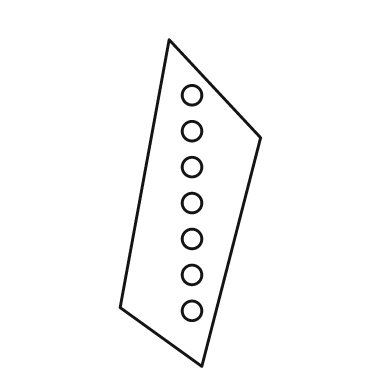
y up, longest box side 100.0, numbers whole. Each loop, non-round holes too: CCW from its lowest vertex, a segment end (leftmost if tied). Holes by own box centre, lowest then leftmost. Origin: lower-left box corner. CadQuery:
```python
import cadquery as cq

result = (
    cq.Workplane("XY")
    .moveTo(25.0, 0.0)
    .lineTo(43.0, 70.0)
    .lineTo(15.0, 100.0)
    .lineTo(0.0, 18.0)
    .close()
    .moveTo(22.0, 17.0)
    .circle(3.0)
    .moveTo(22.0, 28.0)
    .circle(3.0)
    .moveTo(22.0, 39.0)
    .circle(3.0)
    .moveTo(22.0, 50.0)
    .circle(3.0)
    .moveTo(22.0, 61.0)
    .circle(3.0)
    .moveTo(22.0, 72.0)
    .circle(3.0)
    .moveTo(22.0, 83.0)
    .circle(3.0)
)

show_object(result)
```